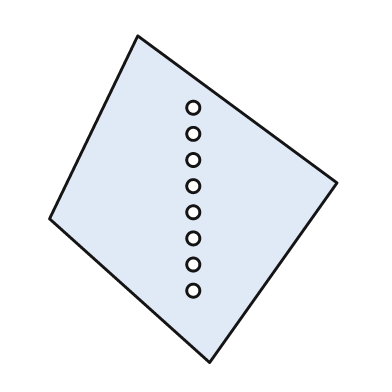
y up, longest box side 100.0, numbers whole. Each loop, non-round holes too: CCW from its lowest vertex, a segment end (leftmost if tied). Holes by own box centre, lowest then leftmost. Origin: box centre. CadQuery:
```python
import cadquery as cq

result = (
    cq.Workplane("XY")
    .moveTo(5.0, -50.0)
    .lineTo(44.0, 5.0)
    .lineTo(-17.0, 50.0)
    .lineTo(-44.0, -6.0)
    .close()
    .moveTo(0.0, -28.0)
    .circle(2.0)
    .moveTo(0.0, -20.0)
    .circle(2.0)
    .moveTo(0.0, -12.0)
    .circle(2.0)
    .moveTo(0.0, -4.0)
    .circle(2.0)
    .moveTo(0.0, 4.0)
    .circle(2.0)
    .moveTo(0.0, 12.0)
    .circle(2.0)
    .moveTo(0.0, 20.0)
    .circle(2.0)
    .moveTo(0.0, 28.0)
    .circle(2.0)
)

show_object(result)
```